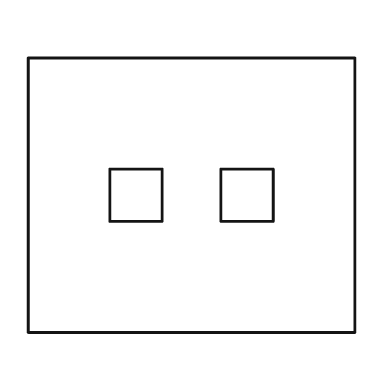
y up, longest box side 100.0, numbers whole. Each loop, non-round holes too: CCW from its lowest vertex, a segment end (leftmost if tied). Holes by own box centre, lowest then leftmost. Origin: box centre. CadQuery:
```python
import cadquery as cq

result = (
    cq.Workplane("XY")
    .moveTo(-50.0, -42.0)
    .lineTo(50.0, -42.0)
    .lineTo(50.0, 42.0)
    .lineTo(-50.0, 42.0)
    .close()
    .moveTo(-25.0, -8.0)
    .lineTo(-9.0, -8.0)
    .lineTo(-9.0, 8.0)
    .lineTo(-25.0, 8.0)
    .close()
    .moveTo(9.0, -8.0)
    .lineTo(25.0, -8.0)
    .lineTo(25.0, 8.0)
    .lineTo(9.0, 8.0)
    .close()
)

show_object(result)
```